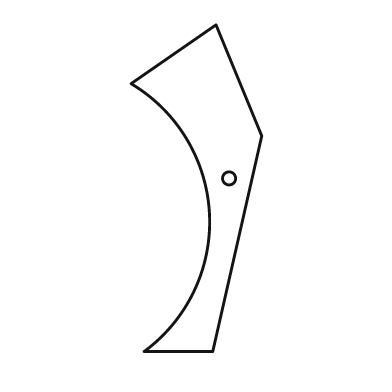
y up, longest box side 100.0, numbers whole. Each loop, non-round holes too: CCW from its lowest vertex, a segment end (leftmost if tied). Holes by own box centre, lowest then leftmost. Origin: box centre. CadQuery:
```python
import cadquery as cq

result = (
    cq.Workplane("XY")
    .moveTo(-16.0, -50.0)
    .lineTo(5.0, -50.0)
    .lineTo(20.0, 16.0)
    .lineTo(6.0, 50.0)
    .lineTo(-20.0, 32.0)
    .threePointArc((4.0, -8.0), (-16.0, -50.0))
    .close()
    .moveTo(10.0, 3.0)
    .circle(2.0)
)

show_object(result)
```